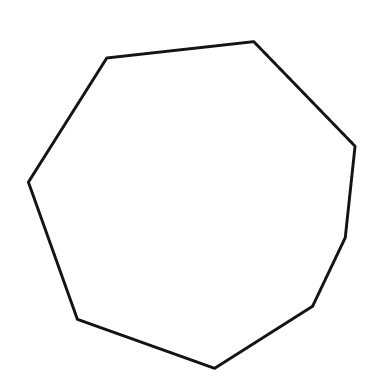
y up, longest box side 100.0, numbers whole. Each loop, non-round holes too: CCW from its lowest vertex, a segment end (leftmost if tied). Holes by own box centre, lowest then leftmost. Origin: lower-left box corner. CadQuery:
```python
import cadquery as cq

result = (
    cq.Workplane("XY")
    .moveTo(57.0, 0.0)
    .lineTo(87.0, 19.0)
    .lineTo(97.0, 40.0)
    .lineTo(100.0, 68.0)
    .lineTo(69.0, 100.0)
    .lineTo(24.0, 95.0)
    .lineTo(0.0, 57.0)
    .lineTo(15.0, 15.0)
    .close()
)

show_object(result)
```